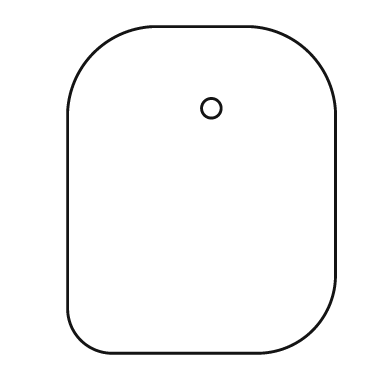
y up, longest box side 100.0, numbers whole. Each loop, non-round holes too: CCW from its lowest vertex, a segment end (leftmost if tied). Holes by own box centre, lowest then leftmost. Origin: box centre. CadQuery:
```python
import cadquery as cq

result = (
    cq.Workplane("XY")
    .moveTo(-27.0, -50.0)
    .lineTo(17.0, -50.0)
    .threePointArc((34.0, -43.0), (41.0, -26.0))
    .lineTo(41.0, 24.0)
    .threePointArc((33.0, 42.0), (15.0, 50.0))
    .lineTo(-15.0, 50.0)
    .threePointArc((-33.0, 42.0), (-41.0, 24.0))
    .lineTo(-41.0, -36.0)
    .threePointArc((-37.0, -46.0), (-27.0, -50.0))
    .close()
    .moveTo(3.0, 25.0)
    .circle(3.0)
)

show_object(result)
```